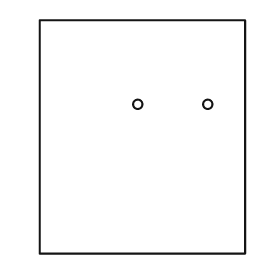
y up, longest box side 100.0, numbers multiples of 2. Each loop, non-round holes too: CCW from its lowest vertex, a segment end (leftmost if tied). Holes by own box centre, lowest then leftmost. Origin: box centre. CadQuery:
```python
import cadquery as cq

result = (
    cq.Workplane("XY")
    .moveTo(-44.0, -50.0)
    .lineTo(44.0, -50.0)
    .lineTo(44.0, 50.0)
    .lineTo(-44.0, 50.0)
    .close()
    .moveTo(-2.0, 14.0)
    .circle(2.0)
    .moveTo(28.0, 14.0)
    .circle(2.0)
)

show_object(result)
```